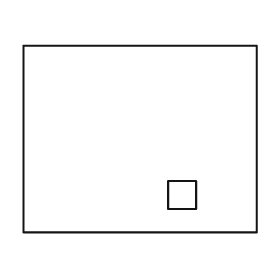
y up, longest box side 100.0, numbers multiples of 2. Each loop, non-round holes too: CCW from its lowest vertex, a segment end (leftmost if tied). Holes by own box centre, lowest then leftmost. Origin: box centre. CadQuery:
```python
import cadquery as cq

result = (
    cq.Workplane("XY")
    .moveTo(-50.0, -40.0)
    .lineTo(50.0, -40.0)
    .lineTo(50.0, 40.0)
    .lineTo(-50.0, 40.0)
    .close()
    .moveTo(12.0, -30.0)
    .lineTo(24.0, -30.0)
    .lineTo(24.0, -18.0)
    .lineTo(12.0, -18.0)
    .close()
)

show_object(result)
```